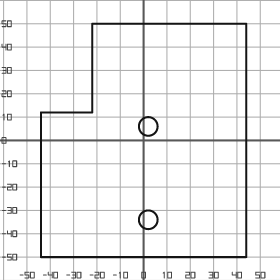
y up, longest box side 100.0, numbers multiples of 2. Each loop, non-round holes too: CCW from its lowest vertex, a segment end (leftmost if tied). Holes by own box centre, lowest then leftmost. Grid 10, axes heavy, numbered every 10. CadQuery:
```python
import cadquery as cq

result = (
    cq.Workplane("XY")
    .moveTo(-44.0, -50.0)
    .lineTo(44.0, -50.0)
    .lineTo(44.0, 50.0)
    .lineTo(-22.0, 50.0)
    .lineTo(-22.0, 12.0)
    .lineTo(-44.0, 12.0)
    .close()
    .moveTo(2.0, -34.0)
    .circle(4.0)
    .moveTo(2.0, 6.0)
    .circle(4.0)
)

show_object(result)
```